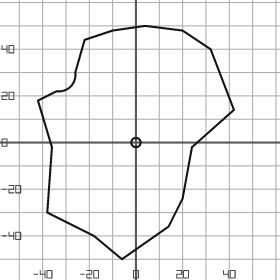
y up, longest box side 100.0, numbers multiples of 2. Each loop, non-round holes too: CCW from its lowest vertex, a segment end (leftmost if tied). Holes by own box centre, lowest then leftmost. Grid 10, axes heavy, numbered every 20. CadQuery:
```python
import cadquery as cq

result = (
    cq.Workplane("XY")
    .moveTo(-6.0, -50.0)
    .lineTo(14.0, -36.0)
    .lineTo(20.0, -24.0)
    .lineTo(24.0, -2.0)
    .lineTo(42.0, 14.0)
    .lineTo(32.0, 40.0)
    .lineTo(20.0, 48.0)
    .lineTo(4.0, 50.0)
    .lineTo(-10.0, 48.0)
    .lineTo(-22.0, 44.0)
    .lineTo(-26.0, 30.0)
    .threePointArc((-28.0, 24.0), (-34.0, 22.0))
    .lineTo(-42.0, 18.0)
    .lineTo(-36.0, -2.0)
    .lineTo(-38.0, -30.0)
    .lineTo(-18.0, -40.0)
    .close()
    .moveTo(0.0, 0.0)
    .circle(2.0)
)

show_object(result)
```